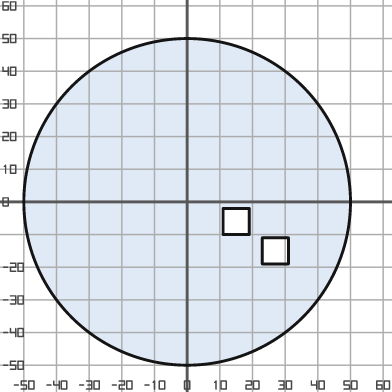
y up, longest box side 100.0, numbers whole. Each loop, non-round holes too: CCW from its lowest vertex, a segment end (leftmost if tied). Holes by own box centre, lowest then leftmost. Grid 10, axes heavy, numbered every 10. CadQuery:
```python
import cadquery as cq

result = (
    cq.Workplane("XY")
    .moveTo(0.0, 0.0)
    .circle(50.0)
    .moveTo(23.0, -19.0)
    .lineTo(31.0, -19.0)
    .lineTo(31.0, -11.0)
    .lineTo(23.0, -11.0)
    .close()
    .moveTo(11.0, -10.0)
    .lineTo(19.0, -10.0)
    .lineTo(19.0, -2.0)
    .lineTo(11.0, -2.0)
    .close()
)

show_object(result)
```